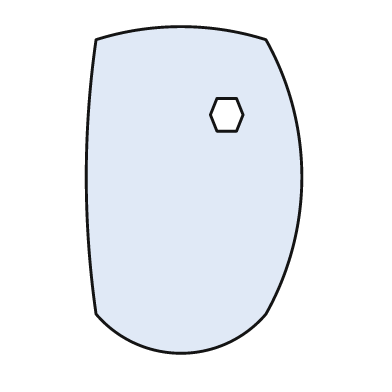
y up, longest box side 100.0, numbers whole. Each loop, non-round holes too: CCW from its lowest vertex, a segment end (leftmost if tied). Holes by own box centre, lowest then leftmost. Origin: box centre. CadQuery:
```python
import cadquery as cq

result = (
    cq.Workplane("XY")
    .moveTo(-30.0, -38.0)
    .threePointArc((-4.0, -50.0), (22.0, -38.0))
    .threePointArc((33.0, 4.0), (22.0, 46.0))
    .threePointArc((-4.0, 50.0), (-30.0, 46.0))
    .threePointArc((-33.0, 4.0), (-30.0, -38.0))
    .close()
    .moveTo(7.0, 18.0)
    .lineTo(13.0, 18.0)
    .lineTo(15.0, 23.0)
    .lineTo(13.0, 28.0)
    .lineTo(7.0, 28.0)
    .lineTo(5.0, 23.0)
    .close()
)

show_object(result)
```